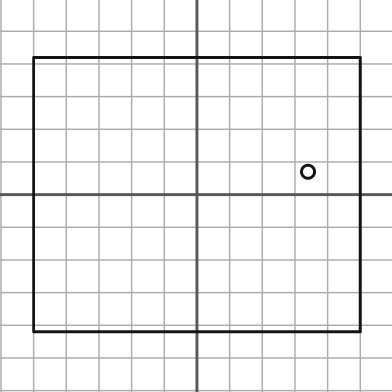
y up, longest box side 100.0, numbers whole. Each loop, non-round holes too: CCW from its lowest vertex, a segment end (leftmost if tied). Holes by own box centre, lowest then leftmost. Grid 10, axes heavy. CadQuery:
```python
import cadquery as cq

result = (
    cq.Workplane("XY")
    .moveTo(-50.0, -42.0)
    .lineTo(50.0, -42.0)
    .lineTo(50.0, 42.0)
    .lineTo(-50.0, 42.0)
    .close()
    .moveTo(34.0, 7.0)
    .circle(2.0)
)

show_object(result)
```